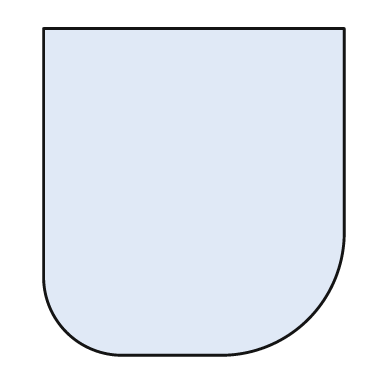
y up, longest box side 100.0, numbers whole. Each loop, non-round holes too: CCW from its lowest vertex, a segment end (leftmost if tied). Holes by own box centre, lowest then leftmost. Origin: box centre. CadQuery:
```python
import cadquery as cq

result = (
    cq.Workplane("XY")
    .moveTo(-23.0, -50.0)
    .lineTo(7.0, -50.0)
    .threePointArc((35.0, -39.0), (46.0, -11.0))
    .lineTo(46.0, 50.0)
    .lineTo(-46.0, 50.0)
    .lineTo(-46.0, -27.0)
    .threePointArc((-39.0, -43.0), (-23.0, -50.0))
    .close()
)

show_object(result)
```